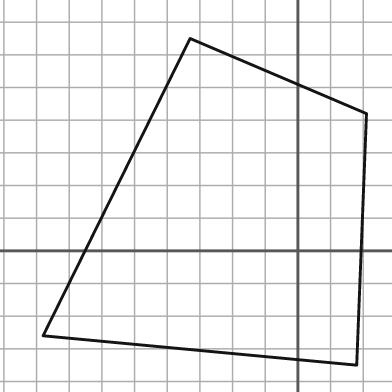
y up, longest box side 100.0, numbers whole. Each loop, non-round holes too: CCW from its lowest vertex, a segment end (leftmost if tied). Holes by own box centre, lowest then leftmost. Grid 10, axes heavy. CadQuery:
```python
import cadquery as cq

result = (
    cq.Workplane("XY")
    .moveTo(18.0, -35.0)
    .lineTo(21.0, 42.0)
    .lineTo(-33.0, 65.0)
    .lineTo(-78.0, -26.0)
    .close()
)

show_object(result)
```